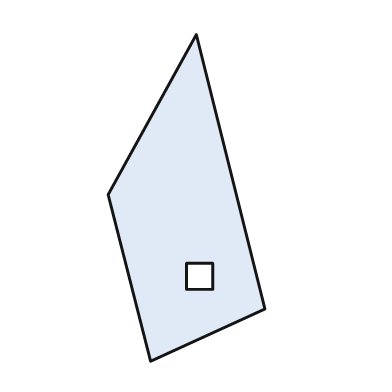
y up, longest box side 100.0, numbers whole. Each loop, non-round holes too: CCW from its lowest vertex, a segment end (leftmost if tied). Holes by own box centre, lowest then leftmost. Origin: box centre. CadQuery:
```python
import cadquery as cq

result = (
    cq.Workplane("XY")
    .moveTo(-11.0, -50.0)
    .lineTo(24.0, -34.0)
    .lineTo(3.0, 50.0)
    .lineTo(-24.0, 1.0)
    .close()
    .moveTo(0.0, -28.0)
    .lineTo(8.0, -28.0)
    .lineTo(8.0, -20.0)
    .lineTo(0.0, -20.0)
    .close()
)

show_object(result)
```